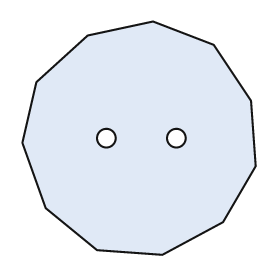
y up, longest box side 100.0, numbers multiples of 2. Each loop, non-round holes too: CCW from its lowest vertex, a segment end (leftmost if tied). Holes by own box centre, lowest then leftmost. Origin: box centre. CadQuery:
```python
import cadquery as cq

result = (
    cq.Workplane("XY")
    .moveTo(10.0, -50.0)
    .lineTo(36.0, -36.0)
    .lineTo(50.0, -12.0)
    .lineTo(48.0, 16.0)
    .lineTo(32.0, 40.0)
    .lineTo(6.0, 50.0)
    .lineTo(-22.0, 44.0)
    .lineTo(-44.0, 24.0)
    .lineTo(-50.0, -2.0)
    .lineTo(-40.0, -30.0)
    .lineTo(-18.0, -48.0)
    .close()
    .moveTo(-14.0, 0.0)
    .circle(4.0)
    .moveTo(16.0, 0.0)
    .circle(4.0)
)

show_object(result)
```